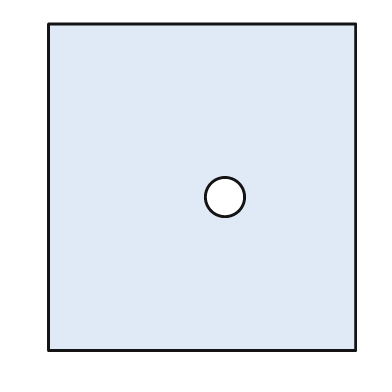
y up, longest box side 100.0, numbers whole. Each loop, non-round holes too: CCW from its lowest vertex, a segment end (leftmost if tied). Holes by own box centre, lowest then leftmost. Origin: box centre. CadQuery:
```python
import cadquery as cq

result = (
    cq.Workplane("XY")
    .moveTo(-47.0, -50.0)
    .lineTo(47.0, -50.0)
    .lineTo(47.0, 50.0)
    .lineTo(-47.0, 50.0)
    .close()
    .moveTo(7.0, -3.0)
    .circle(6.0)
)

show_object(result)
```